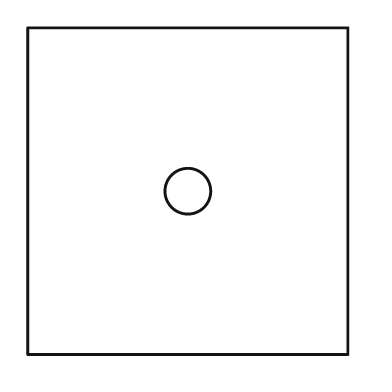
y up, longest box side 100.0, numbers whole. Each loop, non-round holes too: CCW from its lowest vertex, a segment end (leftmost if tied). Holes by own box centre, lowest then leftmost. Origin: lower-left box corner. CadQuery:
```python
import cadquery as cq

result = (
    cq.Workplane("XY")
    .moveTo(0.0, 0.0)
    .lineTo(98.0, 0.0)
    .lineTo(98.0, 100.0)
    .lineTo(0.0, 100.0)
    .close()
    .moveTo(49.0, 50.0)
    .circle(7.0)
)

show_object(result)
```